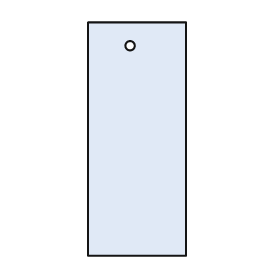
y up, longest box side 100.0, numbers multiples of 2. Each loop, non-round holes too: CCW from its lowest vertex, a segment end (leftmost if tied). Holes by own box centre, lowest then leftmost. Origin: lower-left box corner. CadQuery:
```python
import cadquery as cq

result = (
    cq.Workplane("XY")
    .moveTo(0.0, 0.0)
    .lineTo(42.0, 0.0)
    .lineTo(42.0, 100.0)
    .lineTo(0.0, 100.0)
    .close()
    .moveTo(18.0, 90.0)
    .circle(2.0)
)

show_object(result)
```